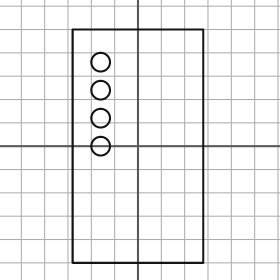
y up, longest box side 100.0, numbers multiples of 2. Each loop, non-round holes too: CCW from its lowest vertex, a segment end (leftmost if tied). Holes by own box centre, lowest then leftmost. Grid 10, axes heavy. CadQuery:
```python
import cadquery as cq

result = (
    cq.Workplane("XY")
    .moveTo(-28.0, -50.0)
    .lineTo(28.0, -50.0)
    .lineTo(28.0, 50.0)
    .lineTo(-28.0, 50.0)
    .close()
    .moveTo(-16.0, 0.0)
    .circle(4.0)
    .moveTo(-16.0, 12.0)
    .circle(4.0)
    .moveTo(-16.0, 24.0)
    .circle(4.0)
    .moveTo(-16.0, 36.0)
    .circle(4.0)
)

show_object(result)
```